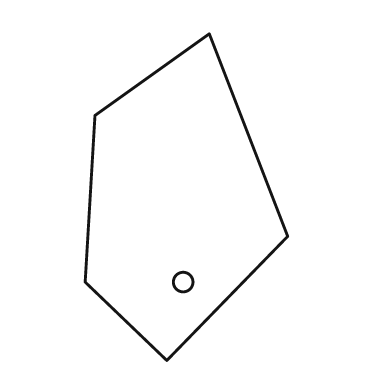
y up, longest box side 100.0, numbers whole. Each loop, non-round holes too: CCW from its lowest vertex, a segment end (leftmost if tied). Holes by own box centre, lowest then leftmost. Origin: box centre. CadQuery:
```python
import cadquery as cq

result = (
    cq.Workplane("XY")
    .moveTo(-6.0, -50.0)
    .lineTo(31.0, -12.0)
    .lineTo(7.0, 50.0)
    .lineTo(-28.0, 25.0)
    .lineTo(-31.0, -26.0)
    .close()
    .moveTo(-1.0, -26.0)
    .circle(3.0)
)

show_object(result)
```